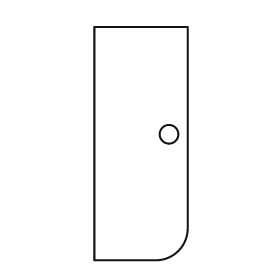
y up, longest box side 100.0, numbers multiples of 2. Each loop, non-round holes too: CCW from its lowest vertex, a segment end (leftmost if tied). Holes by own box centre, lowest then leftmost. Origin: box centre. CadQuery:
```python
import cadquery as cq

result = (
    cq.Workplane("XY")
    .moveTo(-20.0, -50.0)
    .lineTo(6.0, -50.0)
    .threePointArc((16.0, -46.0), (20.0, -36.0))
    .lineTo(20.0, 50.0)
    .lineTo(-20.0, 50.0)
    .close()
    .moveTo(12.0, 4.0)
    .circle(4.0)
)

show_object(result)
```